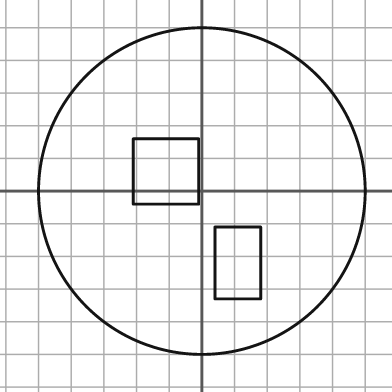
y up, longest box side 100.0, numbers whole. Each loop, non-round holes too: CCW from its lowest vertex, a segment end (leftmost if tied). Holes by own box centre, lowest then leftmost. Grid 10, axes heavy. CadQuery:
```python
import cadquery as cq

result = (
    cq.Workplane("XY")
    .moveTo(0.0, 0.0)
    .circle(50.0)
    .moveTo(4.0, -33.0)
    .lineTo(18.0, -33.0)
    .lineTo(18.0, -11.0)
    .lineTo(4.0, -11.0)
    .close()
    .moveTo(-21.0, -4.0)
    .lineTo(-1.0, -4.0)
    .lineTo(-1.0, 16.0)
    .lineTo(-21.0, 16.0)
    .close()
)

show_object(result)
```